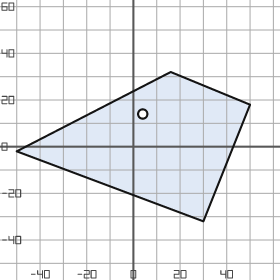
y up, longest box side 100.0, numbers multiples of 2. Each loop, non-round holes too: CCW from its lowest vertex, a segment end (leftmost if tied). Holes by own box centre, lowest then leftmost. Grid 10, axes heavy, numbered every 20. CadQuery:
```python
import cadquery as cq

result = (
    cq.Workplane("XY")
    .moveTo(30.0, -32.0)
    .lineTo(50.0, 18.0)
    .lineTo(16.0, 32.0)
    .lineTo(-50.0, -2.0)
    .close()
    .moveTo(4.0, 14.0)
    .circle(2.0)
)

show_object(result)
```